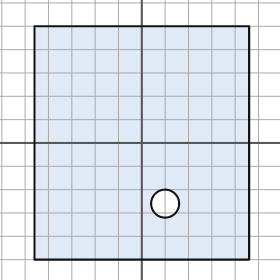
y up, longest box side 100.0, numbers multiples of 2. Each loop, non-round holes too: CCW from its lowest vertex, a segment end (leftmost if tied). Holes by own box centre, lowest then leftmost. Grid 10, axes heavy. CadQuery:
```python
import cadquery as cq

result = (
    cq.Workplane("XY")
    .moveTo(-46.0, -50.0)
    .lineTo(46.0, -50.0)
    .lineTo(46.0, 50.0)
    .lineTo(-46.0, 50.0)
    .close()
    .moveTo(10.0, -26.0)
    .circle(6.0)
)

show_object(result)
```